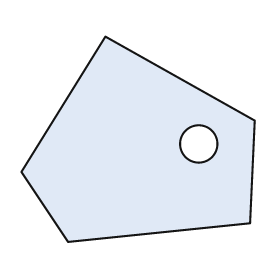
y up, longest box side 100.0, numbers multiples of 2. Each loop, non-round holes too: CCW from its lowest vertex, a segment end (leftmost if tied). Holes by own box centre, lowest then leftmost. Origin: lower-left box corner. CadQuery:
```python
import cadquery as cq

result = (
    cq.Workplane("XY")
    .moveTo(20.0, 0.0)
    .lineTo(98.0, 8.0)
    .lineTo(100.0, 52.0)
    .lineTo(36.0, 88.0)
    .lineTo(0.0, 30.0)
    .close()
    .moveTo(76.0, 42.0)
    .circle(8.0)
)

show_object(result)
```